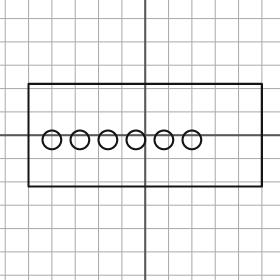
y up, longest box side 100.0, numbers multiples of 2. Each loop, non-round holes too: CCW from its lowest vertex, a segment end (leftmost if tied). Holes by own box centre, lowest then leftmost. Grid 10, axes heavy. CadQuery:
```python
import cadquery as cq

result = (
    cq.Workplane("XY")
    .moveTo(-50.0, -22.0)
    .lineTo(50.0, -22.0)
    .lineTo(50.0, 22.0)
    .lineTo(-50.0, 22.0)
    .close()
    .moveTo(-40.0, -2.0)
    .circle(4.0)
    .moveTo(-28.0, -2.0)
    .circle(4.0)
    .moveTo(-16.0, -2.0)
    .circle(4.0)
    .moveTo(-4.0, -2.0)
    .circle(4.0)
    .moveTo(8.0, -2.0)
    .circle(4.0)
    .moveTo(20.0, -2.0)
    .circle(4.0)
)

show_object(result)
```